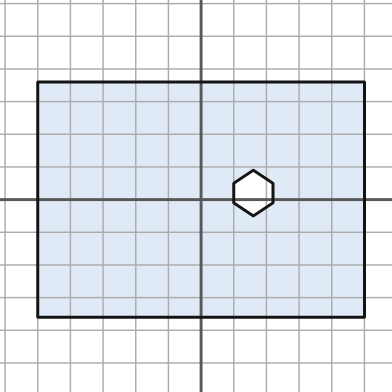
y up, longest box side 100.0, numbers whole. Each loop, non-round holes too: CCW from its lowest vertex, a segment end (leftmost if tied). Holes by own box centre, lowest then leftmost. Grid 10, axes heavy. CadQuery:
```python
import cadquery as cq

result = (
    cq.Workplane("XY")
    .moveTo(-50.0, -36.0)
    .lineTo(50.0, -36.0)
    .lineTo(50.0, 36.0)
    .lineTo(-50.0, 36.0)
    .close()
    .moveTo(16.0, -5.0)
    .lineTo(22.0, -1.0)
    .lineTo(22.0, 5.0)
    .lineTo(16.0, 9.0)
    .lineTo(10.0, 5.0)
    .lineTo(10.0, -1.0)
    .close()
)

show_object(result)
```